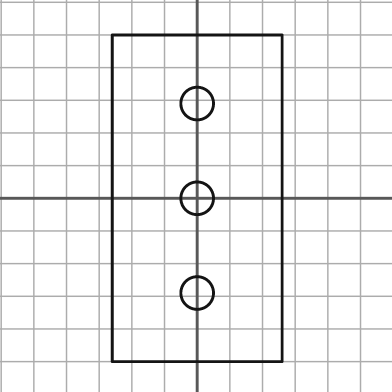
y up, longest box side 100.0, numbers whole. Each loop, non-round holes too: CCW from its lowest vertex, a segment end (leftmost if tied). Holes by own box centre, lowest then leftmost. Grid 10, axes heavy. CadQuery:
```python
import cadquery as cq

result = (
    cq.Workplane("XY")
    .moveTo(-26.0, -50.0)
    .lineTo(26.0, -50.0)
    .lineTo(26.0, 50.0)
    .lineTo(-26.0, 50.0)
    .close()
    .moveTo(0.0, -29.0)
    .circle(5.0)
    .moveTo(0.0, 0.0)
    .circle(5.0)
    .moveTo(0.0, 29.0)
    .circle(5.0)
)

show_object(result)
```